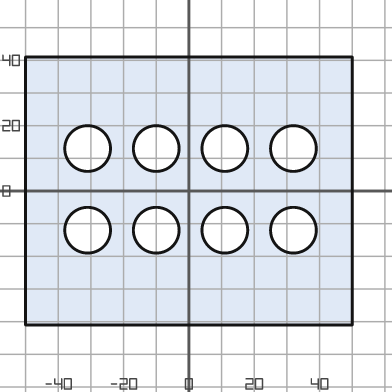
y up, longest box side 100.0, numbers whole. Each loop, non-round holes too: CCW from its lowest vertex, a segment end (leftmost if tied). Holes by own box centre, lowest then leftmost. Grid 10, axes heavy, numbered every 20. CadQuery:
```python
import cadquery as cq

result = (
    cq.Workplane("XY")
    .moveTo(-50.0, -41.0)
    .lineTo(50.0, -41.0)
    .lineTo(50.0, 41.0)
    .lineTo(-50.0, 41.0)
    .close()
    .moveTo(-31.0, -12.0)
    .circle(7.0)
    .moveTo(-10.0, -12.0)
    .circle(7.0)
    .moveTo(11.0, -12.0)
    .circle(7.0)
    .moveTo(32.0, -12.0)
    .circle(7.0)
    .moveTo(-31.0, 13.0)
    .circle(7.0)
    .moveTo(-10.0, 13.0)
    .circle(7.0)
    .moveTo(11.0, 13.0)
    .circle(7.0)
    .moveTo(32.0, 13.0)
    .circle(7.0)
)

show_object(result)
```